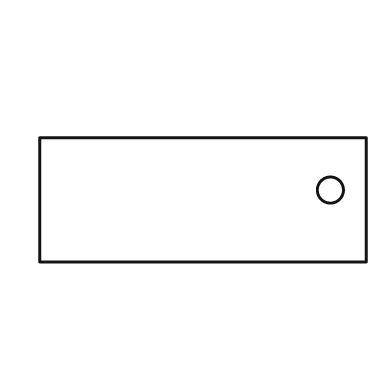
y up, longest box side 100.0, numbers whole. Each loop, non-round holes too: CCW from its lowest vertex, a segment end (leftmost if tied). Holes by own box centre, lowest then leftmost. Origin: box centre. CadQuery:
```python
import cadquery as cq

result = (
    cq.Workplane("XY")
    .moveTo(-50.0, -19.0)
    .lineTo(50.0, -19.0)
    .lineTo(50.0, 19.0)
    .lineTo(-50.0, 19.0)
    .close()
    .moveTo(39.0, 3.0)
    .circle(4.0)
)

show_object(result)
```